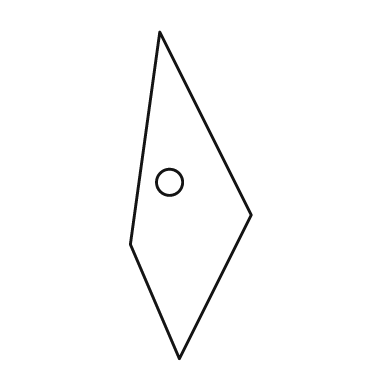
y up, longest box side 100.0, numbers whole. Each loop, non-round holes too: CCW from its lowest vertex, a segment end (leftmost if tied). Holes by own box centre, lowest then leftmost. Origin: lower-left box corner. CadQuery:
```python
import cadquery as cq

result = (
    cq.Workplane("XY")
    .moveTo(15.0, 0.0)
    .lineTo(37.0, 44.0)
    .lineTo(9.0, 100.0)
    .lineTo(0.0, 35.0)
    .close()
    .moveTo(12.0, 54.0)
    .circle(4.0)
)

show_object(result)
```